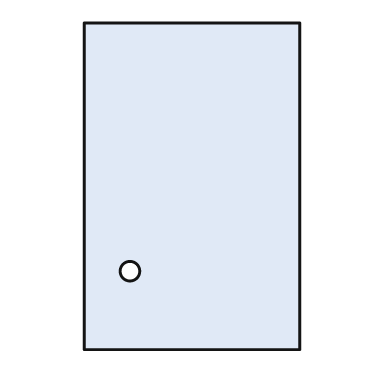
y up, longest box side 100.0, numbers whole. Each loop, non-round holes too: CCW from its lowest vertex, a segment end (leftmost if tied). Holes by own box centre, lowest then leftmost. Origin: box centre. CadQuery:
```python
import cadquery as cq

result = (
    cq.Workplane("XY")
    .moveTo(-33.0, -50.0)
    .lineTo(33.0, -50.0)
    .lineTo(33.0, 50.0)
    .lineTo(-33.0, 50.0)
    .close()
    .moveTo(-19.0, -26.0)
    .circle(3.0)
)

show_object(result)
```